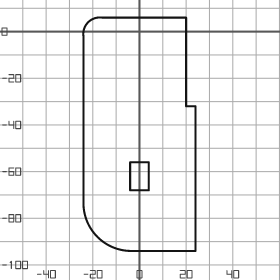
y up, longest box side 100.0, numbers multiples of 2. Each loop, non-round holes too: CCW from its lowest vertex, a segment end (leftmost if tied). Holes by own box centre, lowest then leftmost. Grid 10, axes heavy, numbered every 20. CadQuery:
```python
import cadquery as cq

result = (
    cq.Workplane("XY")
    .moveTo(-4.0, -94.0)
    .lineTo(24.0, -94.0)
    .lineTo(24.0, -32.0)
    .lineTo(20.0, -32.0)
    .lineTo(20.0, 6.0)
    .lineTo(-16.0, 6.0)
    .threePointArc((-22.0, 4.0), (-24.0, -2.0))
    .lineTo(-24.0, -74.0)
    .threePointArc((-18.0, -88.0), (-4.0, -94.0))
    .close()
    .moveTo(-4.0, -68.0)
    .lineTo(4.0, -68.0)
    .lineTo(4.0, -56.0)
    .lineTo(-4.0, -56.0)
    .close()
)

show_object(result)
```